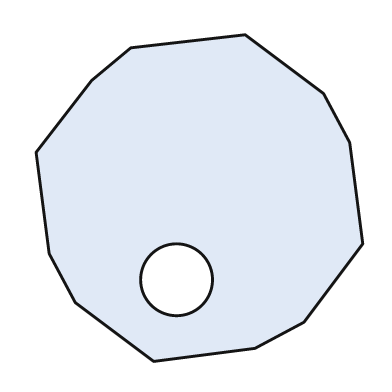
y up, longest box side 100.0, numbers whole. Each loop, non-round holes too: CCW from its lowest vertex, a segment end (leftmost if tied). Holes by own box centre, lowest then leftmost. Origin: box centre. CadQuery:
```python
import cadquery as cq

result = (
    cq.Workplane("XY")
    .moveTo(-14.0, -50.0)
    .lineTo(17.0, -46.0)
    .lineTo(32.0, -38.0)
    .lineTo(50.0, -14.0)
    .lineTo(46.0, 17.0)
    .lineTo(38.0, 32.0)
    .lineTo(14.0, 50.0)
    .lineTo(-21.0, 46.0)
    .lineTo(-33.0, 36.0)
    .lineTo(-50.0, 14.0)
    .lineTo(-46.0, -17.0)
    .lineTo(-38.0, -32.0)
    .close()
    .moveTo(-7.0, -25.0)
    .circle(11.0)
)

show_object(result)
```